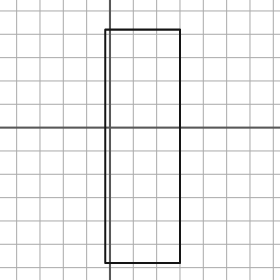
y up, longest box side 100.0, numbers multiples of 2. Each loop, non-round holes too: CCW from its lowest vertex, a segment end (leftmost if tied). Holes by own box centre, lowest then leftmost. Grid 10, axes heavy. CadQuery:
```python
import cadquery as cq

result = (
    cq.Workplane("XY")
    .moveTo(-2.0, -58.0)
    .lineTo(30.0, -58.0)
    .lineTo(30.0, 42.0)
    .lineTo(-2.0, 42.0)
    .close()
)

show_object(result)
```